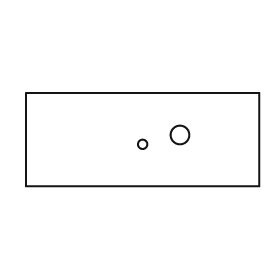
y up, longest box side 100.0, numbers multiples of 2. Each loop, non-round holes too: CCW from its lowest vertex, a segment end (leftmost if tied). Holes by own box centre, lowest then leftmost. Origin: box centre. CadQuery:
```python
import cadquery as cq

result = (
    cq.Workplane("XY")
    .moveTo(-50.0, -20.0)
    .lineTo(50.0, -20.0)
    .lineTo(50.0, 20.0)
    .lineTo(-50.0, 20.0)
    .close()
    .moveTo(0.0, -2.0)
    .circle(2.0)
    .moveTo(16.0, 2.0)
    .circle(4.0)
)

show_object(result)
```